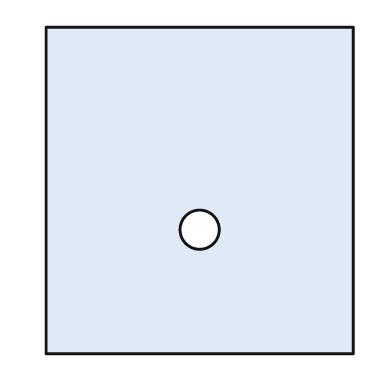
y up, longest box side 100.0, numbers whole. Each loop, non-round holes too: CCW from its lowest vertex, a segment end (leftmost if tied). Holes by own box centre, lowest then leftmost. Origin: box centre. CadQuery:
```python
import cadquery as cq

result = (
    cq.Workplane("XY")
    .moveTo(-47.0, -50.0)
    .lineTo(47.0, -50.0)
    .lineTo(47.0, 50.0)
    .lineTo(-47.0, 50.0)
    .close()
    .moveTo(0.0, -12.0)
    .circle(6.0)
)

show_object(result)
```